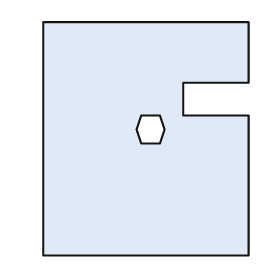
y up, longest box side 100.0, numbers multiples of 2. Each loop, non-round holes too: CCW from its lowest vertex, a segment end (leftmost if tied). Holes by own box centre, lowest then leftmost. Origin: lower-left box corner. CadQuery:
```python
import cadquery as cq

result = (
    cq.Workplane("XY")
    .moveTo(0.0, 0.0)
    .lineTo(88.0, 0.0)
    .lineTo(88.0, 60.0)
    .lineTo(60.0, 60.0)
    .lineTo(60.0, 74.0)
    .lineTo(88.0, 74.0)
    .lineTo(88.0, 100.0)
    .lineTo(0.0, 100.0)
    .close()
    .moveTo(42.0, 48.0)
    .lineTo(50.0, 48.0)
    .lineTo(52.0, 54.0)
    .lineTo(50.0, 60.0)
    .lineTo(42.0, 60.0)
    .lineTo(40.0, 54.0)
    .close()
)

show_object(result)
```